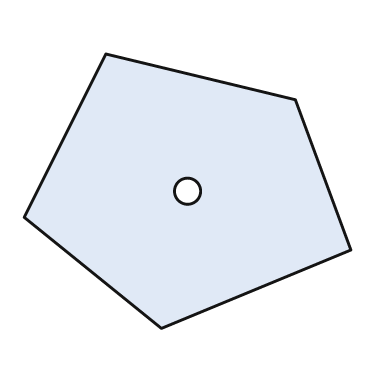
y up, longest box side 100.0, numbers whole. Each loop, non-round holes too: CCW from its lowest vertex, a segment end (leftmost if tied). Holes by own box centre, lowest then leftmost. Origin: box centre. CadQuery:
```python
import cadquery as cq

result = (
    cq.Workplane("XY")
    .moveTo(-8.0, -42.0)
    .lineTo(50.0, -18.0)
    .lineTo(33.0, 28.0)
    .lineTo(-25.0, 42.0)
    .lineTo(-50.0, -8.0)
    .close()
    .moveTo(0.0, 0.0)
    .circle(4.0)
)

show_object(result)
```